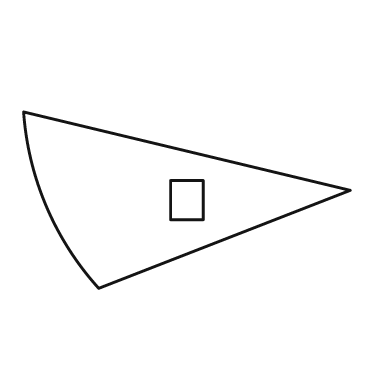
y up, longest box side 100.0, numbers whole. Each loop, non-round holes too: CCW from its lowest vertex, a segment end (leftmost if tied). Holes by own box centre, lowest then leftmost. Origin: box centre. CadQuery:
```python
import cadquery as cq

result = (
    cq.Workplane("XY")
    .moveTo(-27.0, -27.0)
    .lineTo(50.0, 3.0)
    .lineTo(-50.0, 27.0)
    .threePointArc((-43.0, -2.0), (-27.0, -27.0))
    .close()
    .moveTo(-5.0, -6.0)
    .lineTo(5.0, -6.0)
    .lineTo(5.0, 6.0)
    .lineTo(-5.0, 6.0)
    .close()
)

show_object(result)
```